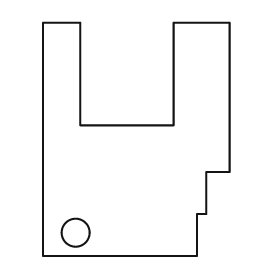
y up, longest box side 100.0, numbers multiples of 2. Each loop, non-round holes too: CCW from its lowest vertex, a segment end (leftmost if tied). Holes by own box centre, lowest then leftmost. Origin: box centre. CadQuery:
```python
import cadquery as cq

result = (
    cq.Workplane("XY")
    .moveTo(-40.0, -50.0)
    .lineTo(26.0, -50.0)
    .lineTo(26.0, -32.0)
    .lineTo(30.0, -32.0)
    .lineTo(30.0, -14.0)
    .lineTo(40.0, -14.0)
    .lineTo(40.0, 50.0)
    .lineTo(16.0, 50.0)
    .lineTo(16.0, 6.0)
    .lineTo(-24.0, 6.0)
    .lineTo(-24.0, 50.0)
    .lineTo(-40.0, 50.0)
    .close()
    .moveTo(-26.0, -40.0)
    .circle(6.0)
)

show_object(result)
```